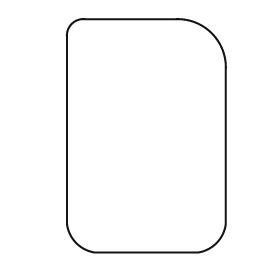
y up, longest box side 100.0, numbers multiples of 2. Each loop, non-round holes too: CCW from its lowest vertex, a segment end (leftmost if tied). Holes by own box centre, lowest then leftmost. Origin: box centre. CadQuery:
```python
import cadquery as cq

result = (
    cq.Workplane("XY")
    .moveTo(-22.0, -50.0)
    .lineTo(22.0, -50.0)
    .threePointArc((30.0, -46.0), (34.0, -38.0))
    .lineTo(34.0, 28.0)
    .threePointArc((28.0, 44.0), (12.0, 50.0))
    .lineTo(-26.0, 50.0)
    .threePointArc((-32.0, 48.0), (-34.0, 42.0))
    .lineTo(-34.0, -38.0)
    .threePointArc((-30.0, -46.0), (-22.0, -50.0))
    .close()
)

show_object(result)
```